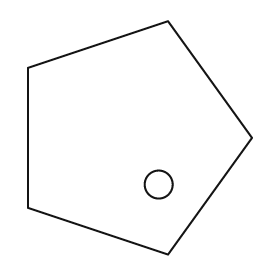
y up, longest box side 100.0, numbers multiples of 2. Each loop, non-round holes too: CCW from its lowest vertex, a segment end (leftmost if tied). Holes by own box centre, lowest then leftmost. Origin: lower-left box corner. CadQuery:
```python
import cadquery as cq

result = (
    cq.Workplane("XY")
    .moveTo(60.0, 0.0)
    .lineTo(96.0, 50.0)
    .lineTo(60.0, 100.0)
    .lineTo(0.0, 80.0)
    .lineTo(0.0, 20.0)
    .close()
    .moveTo(56.0, 30.0)
    .circle(6.0)
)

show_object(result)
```